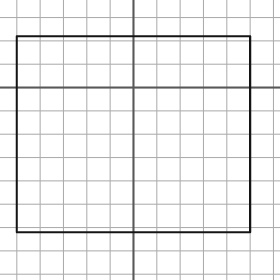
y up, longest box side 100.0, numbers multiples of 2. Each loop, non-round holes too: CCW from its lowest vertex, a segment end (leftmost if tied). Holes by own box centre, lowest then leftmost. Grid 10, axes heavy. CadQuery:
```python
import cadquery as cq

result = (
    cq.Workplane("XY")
    .moveTo(-50.0, -62.0)
    .lineTo(50.0, -62.0)
    .lineTo(50.0, 22.0)
    .lineTo(-50.0, 22.0)
    .close()
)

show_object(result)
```